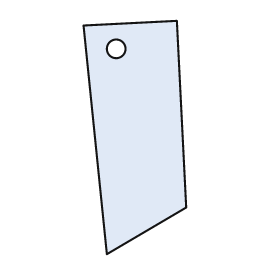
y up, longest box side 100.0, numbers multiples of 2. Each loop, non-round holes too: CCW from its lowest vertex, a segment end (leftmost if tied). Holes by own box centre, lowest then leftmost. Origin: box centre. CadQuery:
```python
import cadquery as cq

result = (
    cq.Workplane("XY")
    .moveTo(-12.0, -50.0)
    .lineTo(22.0, -30.0)
    .lineTo(18.0, 50.0)
    .lineTo(-22.0, 48.0)
    .close()
    .moveTo(-8.0, 38.0)
    .circle(4.0)
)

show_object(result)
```